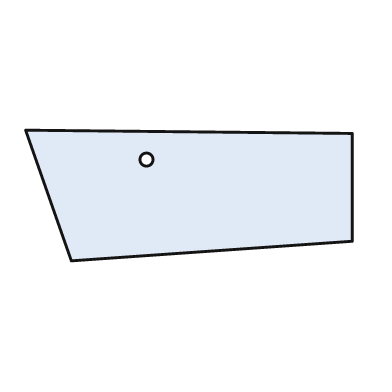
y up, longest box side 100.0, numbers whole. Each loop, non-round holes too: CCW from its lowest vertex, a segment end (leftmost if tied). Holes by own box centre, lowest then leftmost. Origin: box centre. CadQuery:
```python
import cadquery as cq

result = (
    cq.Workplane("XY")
    .moveTo(-36.0, -20.0)
    .lineTo(50.0, -14.0)
    .lineTo(50.0, 19.0)
    .lineTo(-50.0, 20.0)
    .close()
    .moveTo(-13.0, 11.0)
    .circle(2.0)
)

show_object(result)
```